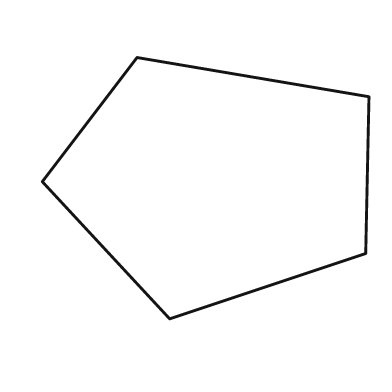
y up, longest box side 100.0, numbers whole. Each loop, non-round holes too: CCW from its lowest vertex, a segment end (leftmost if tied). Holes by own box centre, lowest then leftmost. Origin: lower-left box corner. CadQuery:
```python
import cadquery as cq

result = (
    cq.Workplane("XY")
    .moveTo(39.0, 0.0)
    .lineTo(99.0, 20.0)
    .lineTo(100.0, 68.0)
    .lineTo(29.0, 80.0)
    .lineTo(0.0, 42.0)
    .close()
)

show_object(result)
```